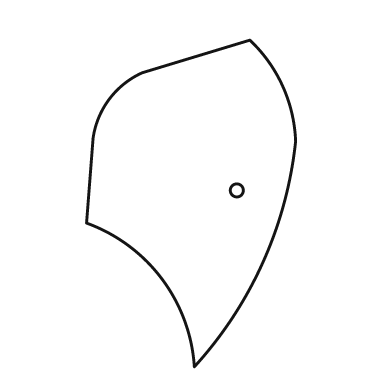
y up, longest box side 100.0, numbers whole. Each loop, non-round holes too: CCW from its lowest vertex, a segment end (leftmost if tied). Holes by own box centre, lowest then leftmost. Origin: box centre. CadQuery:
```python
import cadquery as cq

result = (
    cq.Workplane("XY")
    .moveTo(1.0, -50.0)
    .threePointArc((22.0, -18.0), (32.0, 19.0))
    .threePointArc((28.0, 36.0), (18.0, 50.0))
    .lineTo(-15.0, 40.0)
    .threePointArc((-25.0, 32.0), (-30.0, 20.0))
    .lineTo(-32.0, -6.0)
    .threePointArc((-9.0, -23.0), (1.0, -50.0))
    .close()
    .moveTo(14.0, 4.0)
    .circle(2.0)
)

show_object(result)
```